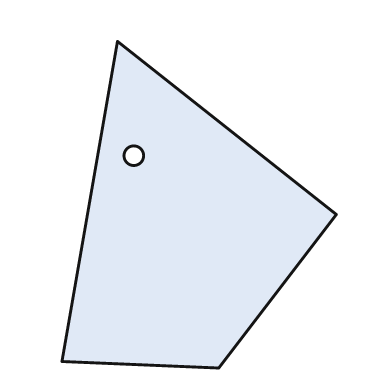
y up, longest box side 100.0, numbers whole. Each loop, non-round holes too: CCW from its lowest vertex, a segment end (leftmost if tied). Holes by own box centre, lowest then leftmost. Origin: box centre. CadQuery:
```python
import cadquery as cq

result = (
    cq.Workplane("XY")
    .moveTo(6.0, -50.0)
    .lineTo(42.0, -3.0)
    .lineTo(-25.0, 50.0)
    .lineTo(-42.0, -48.0)
    .close()
    .moveTo(-20.0, 15.0)
    .circle(3.0)
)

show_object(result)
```